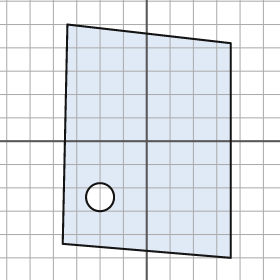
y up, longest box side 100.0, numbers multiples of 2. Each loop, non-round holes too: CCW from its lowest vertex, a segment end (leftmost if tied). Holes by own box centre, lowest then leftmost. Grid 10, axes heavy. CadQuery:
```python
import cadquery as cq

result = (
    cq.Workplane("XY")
    .moveTo(36.0, -50.0)
    .lineTo(36.0, 42.0)
    .lineTo(-34.0, 50.0)
    .lineTo(-36.0, -44.0)
    .close()
    .moveTo(-20.0, -24.0)
    .circle(6.0)
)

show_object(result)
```